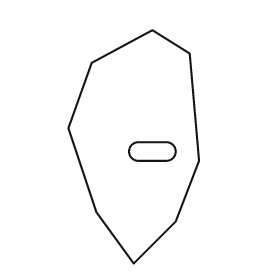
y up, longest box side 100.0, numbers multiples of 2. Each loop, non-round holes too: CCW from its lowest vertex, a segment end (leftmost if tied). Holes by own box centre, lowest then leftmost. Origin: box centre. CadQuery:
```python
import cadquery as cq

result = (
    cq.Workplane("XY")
    .moveTo(0.0, -50.0)
    .lineTo(18.0, -32.0)
    .lineTo(28.0, -6.0)
    .lineTo(24.0, 40.0)
    .lineTo(8.0, 50.0)
    .lineTo(-18.0, 36.0)
    .lineTo(-28.0, 8.0)
    .lineTo(-16.0, -28.0)
    .close()
    .moveTo(2.0, -6.0)
    .lineTo(14.0, -6.0)
    .threePointArc((18.0, -2.0), (14.0, 2.0))
    .lineTo(2.0, 2.0)
    .threePointArc((-2.0, -2.0), (2.0, -6.0))
    .close()
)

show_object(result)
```